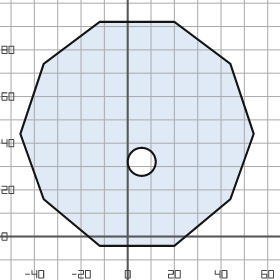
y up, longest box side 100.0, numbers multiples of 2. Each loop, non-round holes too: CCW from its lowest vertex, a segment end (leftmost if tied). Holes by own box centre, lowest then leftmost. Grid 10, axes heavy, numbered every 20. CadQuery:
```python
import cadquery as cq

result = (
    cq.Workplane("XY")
    .moveTo(-12.0, -4.0)
    .lineTo(20.0, -4.0)
    .lineTo(44.0, 16.0)
    .lineTo(54.0, 44.0)
    .lineTo(44.0, 74.0)
    .lineTo(20.0, 92.0)
    .lineTo(-12.0, 92.0)
    .lineTo(-36.0, 74.0)
    .lineTo(-46.0, 44.0)
    .lineTo(-36.0, 16.0)
    .close()
    .moveTo(6.0, 32.0)
    .circle(6.0)
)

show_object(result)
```